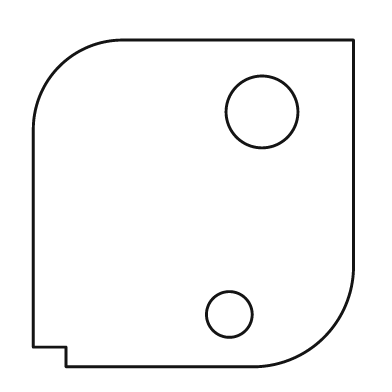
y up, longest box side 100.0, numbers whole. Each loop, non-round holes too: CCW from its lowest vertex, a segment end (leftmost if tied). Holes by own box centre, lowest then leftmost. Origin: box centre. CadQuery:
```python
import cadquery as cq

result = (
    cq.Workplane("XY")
    .moveTo(-39.0, -50.0)
    .lineTo(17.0, -50.0)
    .threePointArc((40.0, -41.0), (49.0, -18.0))
    .lineTo(49.0, 50.0)
    .lineTo(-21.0, 50.0)
    .threePointArc((-41.0, 42.0), (-49.0, 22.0))
    .lineTo(-49.0, -44.0)
    .lineTo(-39.0, -44.0)
    .close()
    .moveTo(11.0, -34.0)
    .circle(7.0)
    .moveTo(21.0, 28.0)
    .circle(11.0)
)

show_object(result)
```